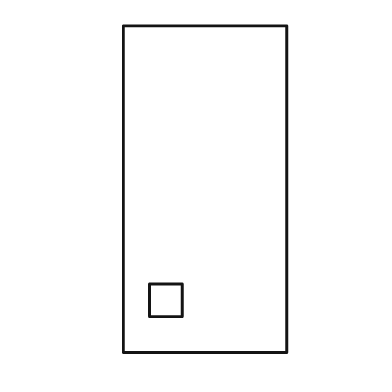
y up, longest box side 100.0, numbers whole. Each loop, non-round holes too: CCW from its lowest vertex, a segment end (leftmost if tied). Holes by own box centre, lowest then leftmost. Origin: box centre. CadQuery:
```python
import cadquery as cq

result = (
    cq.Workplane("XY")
    .moveTo(-25.0, -50.0)
    .lineTo(25.0, -50.0)
    .lineTo(25.0, 50.0)
    .lineTo(-25.0, 50.0)
    .close()
    .moveTo(-17.0, -39.0)
    .lineTo(-7.0, -39.0)
    .lineTo(-7.0, -29.0)
    .lineTo(-17.0, -29.0)
    .close()
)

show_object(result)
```